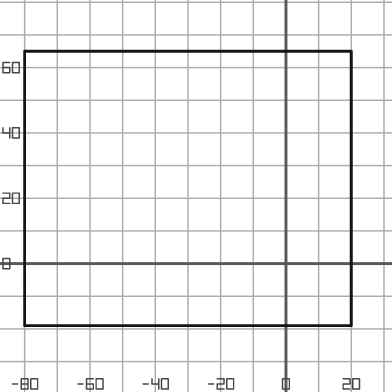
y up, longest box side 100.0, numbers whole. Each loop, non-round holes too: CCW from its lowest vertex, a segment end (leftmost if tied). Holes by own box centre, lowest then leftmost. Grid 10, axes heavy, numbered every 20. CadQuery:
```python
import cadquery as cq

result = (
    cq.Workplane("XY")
    .moveTo(-80.0, -19.0)
    .lineTo(20.0, -19.0)
    .lineTo(20.0, 65.0)
    .lineTo(-80.0, 65.0)
    .close()
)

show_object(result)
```